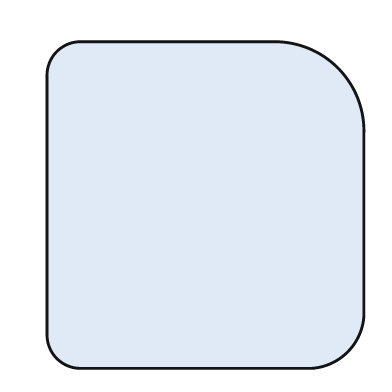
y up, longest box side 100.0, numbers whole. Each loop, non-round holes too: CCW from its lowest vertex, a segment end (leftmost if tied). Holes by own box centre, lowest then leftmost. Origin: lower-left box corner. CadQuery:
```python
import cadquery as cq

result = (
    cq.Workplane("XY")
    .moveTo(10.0, 0.0)
    .lineTo(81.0, 0.0)
    .threePointArc((92.0, 5.0), (97.0, 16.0))
    .lineTo(97.0, 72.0)
    .threePointArc((89.0, 92.0), (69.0, 100.0))
    .lineTo(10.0, 100.0)
    .threePointArc((3.0, 97.0), (0.0, 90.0))
    .lineTo(0.0, 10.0)
    .threePointArc((3.0, 3.0), (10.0, 0.0))
    .close()
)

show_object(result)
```